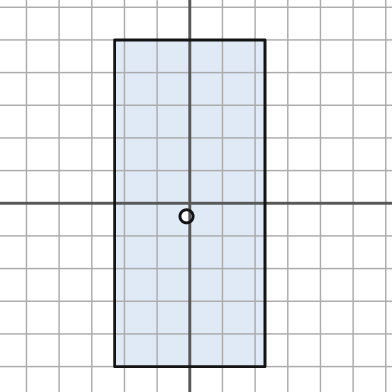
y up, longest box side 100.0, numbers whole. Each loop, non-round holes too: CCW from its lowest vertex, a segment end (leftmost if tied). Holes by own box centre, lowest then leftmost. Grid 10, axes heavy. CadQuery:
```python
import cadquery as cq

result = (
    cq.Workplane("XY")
    .moveTo(-23.0, -50.0)
    .lineTo(23.0, -50.0)
    .lineTo(23.0, 50.0)
    .lineTo(-23.0, 50.0)
    .close()
    .moveTo(-1.0, -4.0)
    .circle(2.0)
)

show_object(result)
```